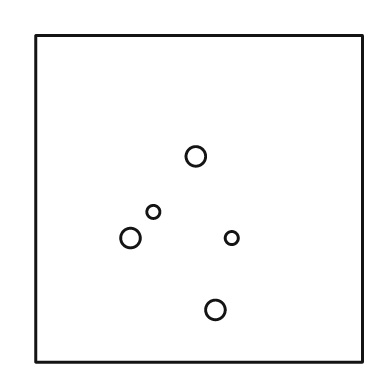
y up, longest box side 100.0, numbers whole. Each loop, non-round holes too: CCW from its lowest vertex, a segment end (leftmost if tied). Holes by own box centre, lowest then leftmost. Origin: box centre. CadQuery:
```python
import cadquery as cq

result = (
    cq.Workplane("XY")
    .moveTo(-50.0, -50.0)
    .lineTo(50.0, -50.0)
    .lineTo(50.0, 50.0)
    .lineTo(-50.0, 50.0)
    .close()
    .moveTo(5.0, -34.0)
    .circle(3.0)
    .moveTo(-21.0, -12.0)
    .circle(3.0)
    .moveTo(10.0, -12.0)
    .circle(2.0)
    .moveTo(-14.0, -4.0)
    .circle(2.0)
    .moveTo(-1.0, 13.0)
    .circle(3.0)
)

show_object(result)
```